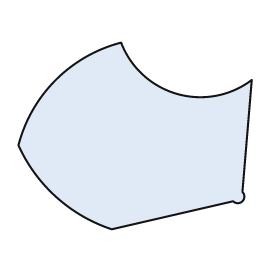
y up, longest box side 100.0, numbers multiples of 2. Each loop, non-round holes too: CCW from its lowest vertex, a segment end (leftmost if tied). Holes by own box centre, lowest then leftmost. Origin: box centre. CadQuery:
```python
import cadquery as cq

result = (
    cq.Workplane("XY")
    .moveTo(-10.0, -40.0)
    .lineTo(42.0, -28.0)
    .threePointArc((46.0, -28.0), (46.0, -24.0))
    .lineTo(50.0, 24.0)
    .threePointArc((18.0, 18.0), (-6.0, 40.0))
    .threePointArc((-34.0, 24.0), (-50.0, -4.0))
    .threePointArc((-34.0, -26.0), (-10.0, -40.0))
    .close()
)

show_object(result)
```